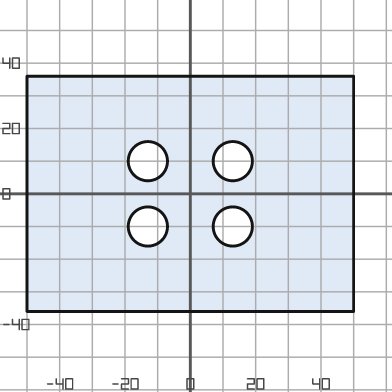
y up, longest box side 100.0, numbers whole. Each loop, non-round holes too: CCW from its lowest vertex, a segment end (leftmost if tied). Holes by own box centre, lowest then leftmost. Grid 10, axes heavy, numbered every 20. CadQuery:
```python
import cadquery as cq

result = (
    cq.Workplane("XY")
    .moveTo(-50.0, -36.0)
    .lineTo(50.0, -36.0)
    .lineTo(50.0, 36.0)
    .lineTo(-50.0, 36.0)
    .close()
    .moveTo(-13.0, -10.0)
    .circle(6.0)
    .moveTo(13.0, -10.0)
    .circle(6.0)
    .moveTo(-13.0, 10.0)
    .circle(6.0)
    .moveTo(13.0, 10.0)
    .circle(6.0)
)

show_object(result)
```